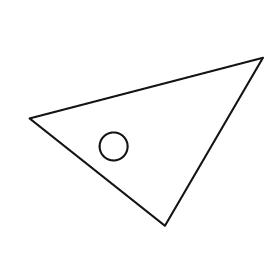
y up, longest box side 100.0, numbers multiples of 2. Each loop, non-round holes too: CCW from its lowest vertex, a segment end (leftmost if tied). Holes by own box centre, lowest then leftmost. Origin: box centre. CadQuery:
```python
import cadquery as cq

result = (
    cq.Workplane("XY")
    .moveTo(8.0, -36.0)
    .lineTo(50.0, 36.0)
    .lineTo(-50.0, 10.0)
    .close()
    .moveTo(-14.0, -2.0)
    .circle(6.0)
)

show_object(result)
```